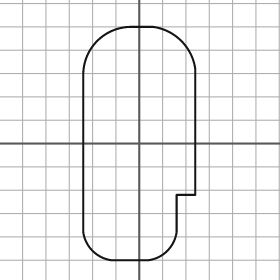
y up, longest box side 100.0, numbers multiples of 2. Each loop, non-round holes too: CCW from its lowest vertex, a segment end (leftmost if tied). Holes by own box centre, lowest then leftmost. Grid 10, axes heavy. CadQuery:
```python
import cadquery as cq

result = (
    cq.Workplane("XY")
    .moveTo(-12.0, -50.0)
    .lineTo(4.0, -50.0)
    .threePointArc((12.0, -46.0), (16.0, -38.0))
    .lineTo(16.0, -22.0)
    .lineTo(24.0, -22.0)
    .lineTo(24.0, 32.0)
    .threePointArc((18.0, 44.0), (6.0, 50.0))
    .lineTo(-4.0, 50.0)
    .threePointArc((-18.0, 44.0), (-24.0, 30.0))
    .lineTo(-24.0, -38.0)
    .threePointArc((-20.0, -46.0), (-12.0, -50.0))
    .close()
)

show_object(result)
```